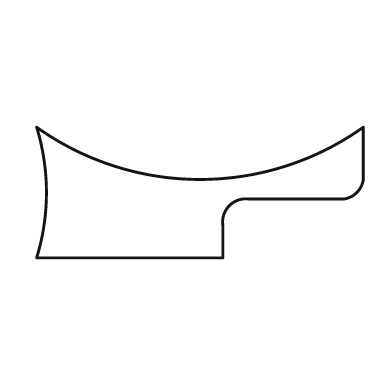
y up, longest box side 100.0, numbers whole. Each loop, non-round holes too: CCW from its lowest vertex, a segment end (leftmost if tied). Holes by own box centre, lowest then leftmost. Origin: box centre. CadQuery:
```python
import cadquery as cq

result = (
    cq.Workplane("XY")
    .moveTo(-50.0, -20.0)
    .lineTo(7.0, -20.0)
    .lineTo(7.0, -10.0)
    .threePointArc((9.0, -4.0), (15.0, -2.0))
    .lineTo(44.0, -2.0)
    .threePointArc((48.0, 0.0), (50.0, 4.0))
    .lineTo(50.0, 20.0)
    .threePointArc((0.0, 4.0), (-50.0, 20.0))
    .threePointArc((-47.0, 0.0), (-50.0, -20.0))
    .close()
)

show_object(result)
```